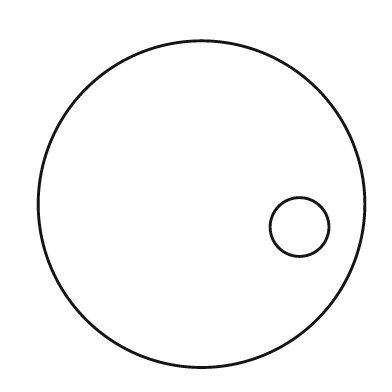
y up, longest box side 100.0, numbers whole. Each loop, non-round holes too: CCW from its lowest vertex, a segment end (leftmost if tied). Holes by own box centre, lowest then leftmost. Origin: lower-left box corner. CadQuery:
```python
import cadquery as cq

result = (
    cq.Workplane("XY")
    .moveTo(50.0, 50.0)
    .circle(50.0)
    .moveTo(80.0, 43.0)
    .circle(9.0)
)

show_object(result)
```